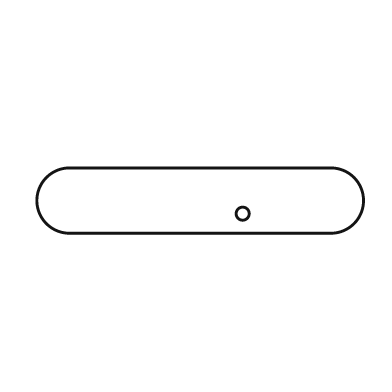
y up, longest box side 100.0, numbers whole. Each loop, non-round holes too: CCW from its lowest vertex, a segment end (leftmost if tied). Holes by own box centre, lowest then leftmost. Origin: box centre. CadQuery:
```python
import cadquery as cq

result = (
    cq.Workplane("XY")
    .moveTo(-40.0, -10.0)
    .lineTo(40.0, -10.0)
    .threePointArc((50.0, 0.0), (40.0, 10.0))
    .lineTo(-40.0, 10.0)
    .threePointArc((-50.0, 0.0), (-40.0, -10.0))
    .close()
    .moveTo(13.0, -4.0)
    .circle(2.0)
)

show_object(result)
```